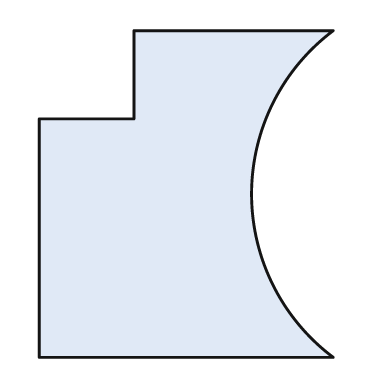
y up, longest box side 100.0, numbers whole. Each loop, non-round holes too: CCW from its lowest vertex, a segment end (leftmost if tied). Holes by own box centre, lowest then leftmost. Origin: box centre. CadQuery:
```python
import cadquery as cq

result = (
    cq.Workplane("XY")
    .moveTo(-45.0, -50.0)
    .lineTo(45.0, -50.0)
    .threePointArc((20.0, 0.0), (45.0, 50.0))
    .lineTo(-16.0, 50.0)
    .lineTo(-16.0, 23.0)
    .lineTo(-45.0, 23.0)
    .close()
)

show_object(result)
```